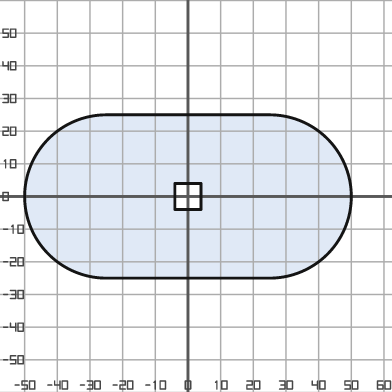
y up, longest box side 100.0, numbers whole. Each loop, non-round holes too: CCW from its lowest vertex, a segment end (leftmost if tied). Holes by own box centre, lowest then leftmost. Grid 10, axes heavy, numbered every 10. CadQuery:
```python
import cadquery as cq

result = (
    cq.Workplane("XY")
    .moveTo(-25.0, -25.0)
    .lineTo(25.0, -25.0)
    .threePointArc((50.0, 0.0), (25.0, 25.0))
    .lineTo(-25.0, 25.0)
    .threePointArc((-50.0, 0.0), (-25.0, -25.0))
    .close()
    .moveTo(-4.0, -4.0)
    .lineTo(4.0, -4.0)
    .lineTo(4.0, 4.0)
    .lineTo(-4.0, 4.0)
    .close()
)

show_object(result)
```